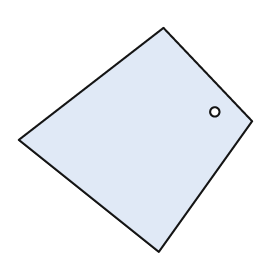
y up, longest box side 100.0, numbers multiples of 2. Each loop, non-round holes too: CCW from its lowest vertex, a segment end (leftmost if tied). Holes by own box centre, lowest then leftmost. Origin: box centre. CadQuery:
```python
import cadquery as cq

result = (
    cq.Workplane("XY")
    .moveTo(10.0, -48.0)
    .lineTo(50.0, 8.0)
    .lineTo(12.0, 48.0)
    .lineTo(-50.0, 0.0)
    .close()
    .moveTo(34.0, 12.0)
    .circle(2.0)
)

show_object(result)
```